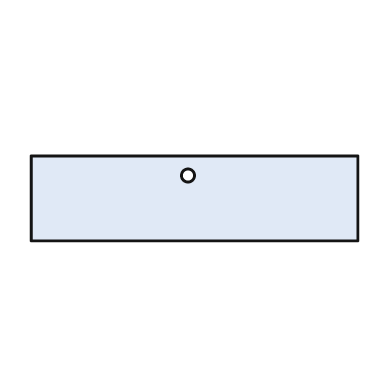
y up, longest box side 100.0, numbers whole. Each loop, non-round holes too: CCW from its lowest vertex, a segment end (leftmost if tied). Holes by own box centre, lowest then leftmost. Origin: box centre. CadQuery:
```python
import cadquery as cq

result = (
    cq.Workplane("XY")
    .moveTo(-50.0, -13.0)
    .lineTo(50.0, -13.0)
    .lineTo(50.0, 13.0)
    .lineTo(-50.0, 13.0)
    .close()
    .moveTo(-2.0, 7.0)
    .circle(2.0)
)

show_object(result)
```